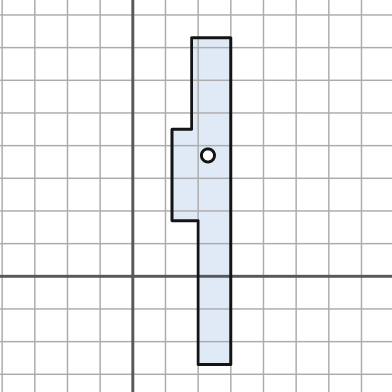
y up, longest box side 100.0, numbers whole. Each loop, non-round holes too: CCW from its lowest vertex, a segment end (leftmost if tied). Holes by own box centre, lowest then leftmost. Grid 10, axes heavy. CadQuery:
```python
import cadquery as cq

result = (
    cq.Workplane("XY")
    .moveTo(20.0, -27.0)
    .lineTo(30.0, -27.0)
    .lineTo(30.0, 73.0)
    .lineTo(18.0, 73.0)
    .lineTo(18.0, 45.0)
    .lineTo(12.0, 45.0)
    .lineTo(12.0, 17.0)
    .lineTo(20.0, 17.0)
    .close()
    .moveTo(23.0, 37.0)
    .circle(2.0)
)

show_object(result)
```